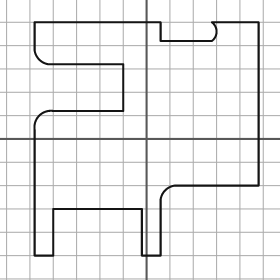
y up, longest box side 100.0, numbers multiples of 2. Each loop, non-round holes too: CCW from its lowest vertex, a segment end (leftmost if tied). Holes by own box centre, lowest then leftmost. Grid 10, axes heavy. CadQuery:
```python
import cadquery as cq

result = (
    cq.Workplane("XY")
    .moveTo(-48.0, -50.0)
    .lineTo(-40.0, -50.0)
    .lineTo(-40.0, -30.0)
    .lineTo(-2.0, -30.0)
    .lineTo(-2.0, -50.0)
    .lineTo(6.0, -50.0)
    .lineTo(6.0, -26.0)
    .threePointArc((8.0, -22.0), (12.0, -20.0))
    .lineTo(48.0, -20.0)
    .lineTo(48.0, 50.0)
    .lineTo(28.0, 50.0)
    .threePointArc((30.0, 46.0), (28.0, 42.0))
    .lineTo(6.0, 42.0)
    .lineTo(6.0, 50.0)
    .lineTo(-48.0, 50.0)
    .lineTo(-48.0, 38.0)
    .threePointArc((-46.0, 34.0), (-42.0, 32.0))
    .lineTo(-10.0, 32.0)
    .lineTo(-10.0, 12.0)
    .lineTo(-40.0, 12.0)
    .threePointArc((-46.0, 10.0), (-48.0, 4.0))
    .close()
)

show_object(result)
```